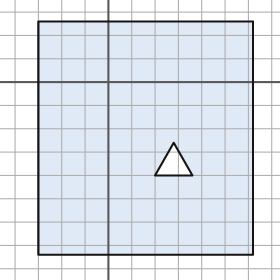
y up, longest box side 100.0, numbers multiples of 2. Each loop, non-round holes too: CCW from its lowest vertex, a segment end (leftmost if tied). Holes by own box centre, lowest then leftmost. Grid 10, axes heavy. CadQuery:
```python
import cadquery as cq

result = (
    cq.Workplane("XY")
    .moveTo(-30.0, -74.0)
    .lineTo(62.0, -74.0)
    .lineTo(62.0, 26.0)
    .lineTo(-30.0, 26.0)
    .close()
    .moveTo(20.0, -40.0)
    .lineTo(36.0, -40.0)
    .lineTo(28.0, -26.0)
    .close()
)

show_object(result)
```